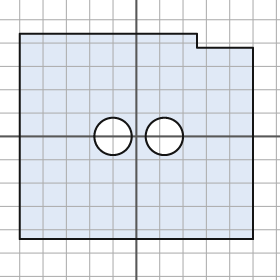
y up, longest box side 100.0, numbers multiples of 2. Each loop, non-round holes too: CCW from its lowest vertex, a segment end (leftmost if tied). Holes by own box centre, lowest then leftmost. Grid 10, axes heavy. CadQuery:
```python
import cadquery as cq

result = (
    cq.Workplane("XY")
    .moveTo(-50.0, -44.0)
    .lineTo(50.0, -44.0)
    .lineTo(50.0, 38.0)
    .lineTo(26.0, 38.0)
    .lineTo(26.0, 44.0)
    .lineTo(-50.0, 44.0)
    .close()
    .moveTo(-10.0, 0.0)
    .circle(8.0)
    .moveTo(12.0, 0.0)
    .circle(8.0)
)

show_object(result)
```